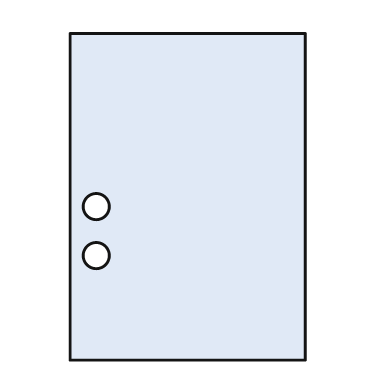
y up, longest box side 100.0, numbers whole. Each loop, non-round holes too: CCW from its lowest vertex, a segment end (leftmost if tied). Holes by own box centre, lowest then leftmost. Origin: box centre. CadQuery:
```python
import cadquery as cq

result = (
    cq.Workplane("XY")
    .moveTo(-36.0, -50.0)
    .lineTo(36.0, -50.0)
    .lineTo(36.0, 50.0)
    .lineTo(-36.0, 50.0)
    .close()
    .moveTo(-28.0, -18.0)
    .circle(4.0)
    .moveTo(-28.0, -3.0)
    .circle(4.0)
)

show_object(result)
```